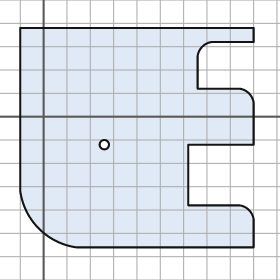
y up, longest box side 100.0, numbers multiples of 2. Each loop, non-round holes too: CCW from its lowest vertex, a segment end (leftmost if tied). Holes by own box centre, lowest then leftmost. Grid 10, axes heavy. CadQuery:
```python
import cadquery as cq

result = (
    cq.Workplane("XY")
    .moveTo(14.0, -56.0)
    .lineTo(90.0, -56.0)
    .lineTo(90.0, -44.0)
    .threePointArc((88.0, -40.0), (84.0, -38.0))
    .lineTo(62.0, -38.0)
    .lineTo(62.0, -12.0)
    .lineTo(90.0, -12.0)
    .lineTo(90.0, 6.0)
    .threePointArc((88.0, 10.0), (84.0, 12.0))
    .lineTo(66.0, 12.0)
    .lineTo(66.0, 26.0)
    .threePointArc((68.0, 30.0), (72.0, 32.0))
    .lineTo(90.0, 32.0)
    .lineTo(90.0, 38.0)
    .lineTo(-10.0, 38.0)
    .lineTo(-10.0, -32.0)
    .threePointArc((-2.0, -48.0), (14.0, -56.0))
    .close()
    .moveTo(26.0, -12.0)
    .circle(2.0)
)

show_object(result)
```